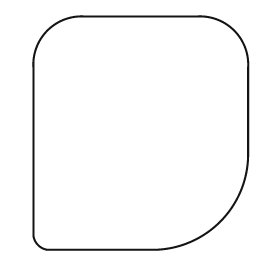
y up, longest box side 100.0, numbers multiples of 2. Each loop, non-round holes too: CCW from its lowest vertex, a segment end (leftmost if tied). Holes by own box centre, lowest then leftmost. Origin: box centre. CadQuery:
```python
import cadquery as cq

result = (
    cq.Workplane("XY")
    .moveTo(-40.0, -50.0)
    .lineTo(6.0, -50.0)
    .threePointArc((34.0, -38.0), (46.0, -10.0))
    .lineTo(46.0, 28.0)
    .threePointArc((40.0, 44.0), (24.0, 50.0))
    .lineTo(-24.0, 50.0)
    .threePointArc((-40.0, 44.0), (-46.0, 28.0))
    .lineTo(-46.0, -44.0)
    .threePointArc((-44.0, -48.0), (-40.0, -50.0))
    .close()
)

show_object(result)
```